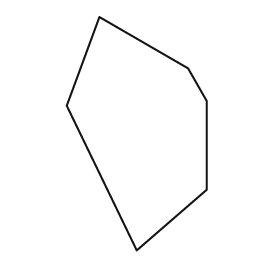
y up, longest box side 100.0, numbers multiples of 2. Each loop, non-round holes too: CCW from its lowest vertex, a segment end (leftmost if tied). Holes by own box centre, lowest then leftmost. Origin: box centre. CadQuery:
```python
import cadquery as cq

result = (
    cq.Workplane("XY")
    .moveTo(0.0, -50.0)
    .lineTo(30.0, -24.0)
    .lineTo(30.0, 14.0)
    .lineTo(22.0, 28.0)
    .lineTo(-16.0, 50.0)
    .lineTo(-30.0, 12.0)
    .close()
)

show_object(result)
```